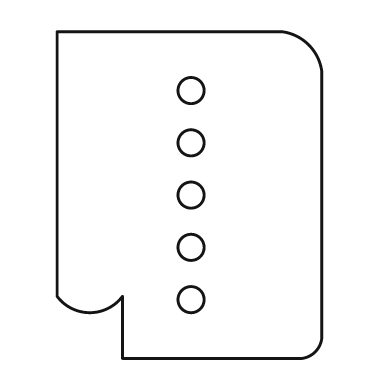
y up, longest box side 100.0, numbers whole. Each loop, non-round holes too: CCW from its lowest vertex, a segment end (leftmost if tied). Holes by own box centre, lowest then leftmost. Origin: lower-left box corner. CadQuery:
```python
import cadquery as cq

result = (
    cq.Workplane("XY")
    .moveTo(20.0, 0.0)
    .lineTo(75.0, 0.0)
    .threePointArc((79.0, 2.0), (81.0, 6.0))
    .lineTo(81.0, 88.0)
    .threePointArc((77.0, 96.0), (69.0, 100.0))
    .lineTo(0.0, 100.0)
    .lineTo(0.0, 19.0)
    .threePointArc((10.0, 14.0), (20.0, 19.0))
    .close()
    .moveTo(41.0, 18.0)
    .circle(4.0)
    .moveTo(41.0, 34.0)
    .circle(4.0)
    .moveTo(41.0, 50.0)
    .circle(4.0)
    .moveTo(41.0, 66.0)
    .circle(4.0)
    .moveTo(41.0, 82.0)
    .circle(4.0)
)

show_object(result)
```